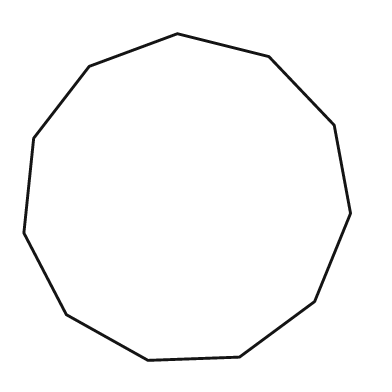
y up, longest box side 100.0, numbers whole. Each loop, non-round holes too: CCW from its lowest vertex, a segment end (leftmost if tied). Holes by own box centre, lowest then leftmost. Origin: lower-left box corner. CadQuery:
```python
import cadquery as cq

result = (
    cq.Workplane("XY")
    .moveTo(38.0, 0.0)
    .lineTo(66.0, 1.0)
    .lineTo(89.0, 18.0)
    .lineTo(100.0, 45.0)
    .lineTo(95.0, 72.0)
    .lineTo(75.0, 93.0)
    .lineTo(47.0, 100.0)
    .lineTo(20.0, 90.0)
    .lineTo(3.0, 68.0)
    .lineTo(0.0, 39.0)
    .lineTo(13.0, 14.0)
    .close()
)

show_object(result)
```